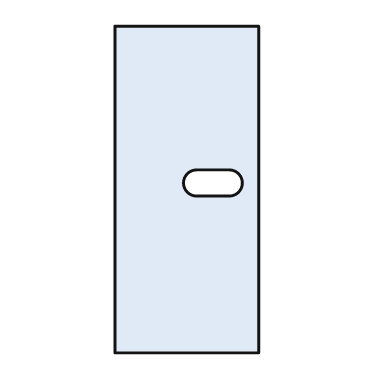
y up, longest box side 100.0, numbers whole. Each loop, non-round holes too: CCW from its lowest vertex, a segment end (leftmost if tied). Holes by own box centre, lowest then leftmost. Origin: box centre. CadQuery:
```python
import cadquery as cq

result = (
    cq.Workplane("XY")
    .moveTo(-22.0, -50.0)
    .lineTo(22.0, -50.0)
    .lineTo(22.0, 50.0)
    .lineTo(-22.0, 50.0)
    .close()
    .moveTo(3.0, -2.0)
    .lineTo(13.0, -2.0)
    .threePointArc((17.0, 2.0), (13.0, 6.0))
    .lineTo(3.0, 6.0)
    .threePointArc((-1.0, 2.0), (3.0, -2.0))
    .close()
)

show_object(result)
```